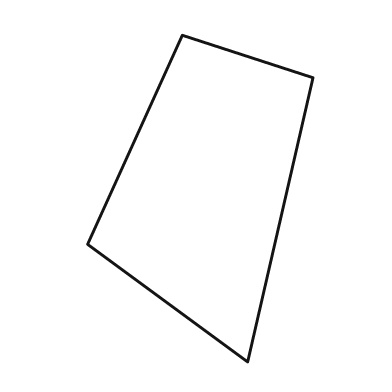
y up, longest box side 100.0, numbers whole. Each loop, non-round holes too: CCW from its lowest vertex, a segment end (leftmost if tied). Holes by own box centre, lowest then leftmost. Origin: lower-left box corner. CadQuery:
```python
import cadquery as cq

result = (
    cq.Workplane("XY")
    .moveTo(49.0, 0.0)
    .lineTo(69.0, 87.0)
    .lineTo(29.0, 100.0)
    .lineTo(0.0, 36.0)
    .close()
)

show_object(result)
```